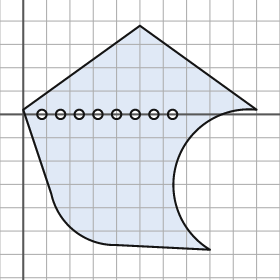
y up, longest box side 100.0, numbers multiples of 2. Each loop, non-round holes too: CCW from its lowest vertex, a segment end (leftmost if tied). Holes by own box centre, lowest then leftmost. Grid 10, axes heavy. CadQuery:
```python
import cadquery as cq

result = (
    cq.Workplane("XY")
    .moveTo(80.0, -58.0)
    .threePointArc((66.0, -20.0), (100.0, 2.0))
    .lineTo(50.0, 38.0)
    .lineTo(0.0, 2.0)
    .lineTo(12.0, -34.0)
    .threePointArc((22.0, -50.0), (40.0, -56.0))
    .close()
    .moveTo(8.0, 0.0)
    .circle(2.0)
    .moveTo(16.0, 0.0)
    .circle(2.0)
    .moveTo(24.0, 0.0)
    .circle(2.0)
    .moveTo(32.0, 0.0)
    .circle(2.0)
    .moveTo(40.0, 0.0)
    .circle(2.0)
    .moveTo(48.0, 0.0)
    .circle(2.0)
    .moveTo(56.0, 0.0)
    .circle(2.0)
    .moveTo(64.0, 0.0)
    .circle(2.0)
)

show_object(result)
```